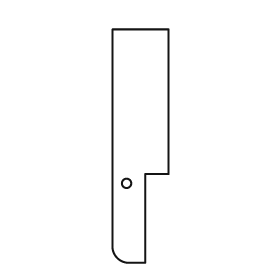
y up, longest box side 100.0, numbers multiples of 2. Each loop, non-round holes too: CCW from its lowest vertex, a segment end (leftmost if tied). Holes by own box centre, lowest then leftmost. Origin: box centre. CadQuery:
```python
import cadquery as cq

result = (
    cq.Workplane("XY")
    .moveTo(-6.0, -50.0)
    .lineTo(2.0, -50.0)
    .lineTo(2.0, -12.0)
    .lineTo(12.0, -12.0)
    .lineTo(12.0, 50.0)
    .lineTo(-12.0, 50.0)
    .lineTo(-12.0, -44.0)
    .threePointArc((-10.0, -48.0), (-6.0, -50.0))
    .close()
    .moveTo(-6.0, -16.0)
    .circle(2.0)
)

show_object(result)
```